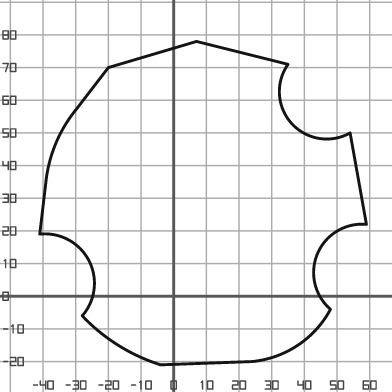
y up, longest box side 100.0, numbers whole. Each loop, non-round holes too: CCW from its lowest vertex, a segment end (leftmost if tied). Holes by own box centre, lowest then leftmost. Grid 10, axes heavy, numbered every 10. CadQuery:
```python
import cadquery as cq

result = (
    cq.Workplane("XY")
    .moveTo(-4.0, -21.0)
    .lineTo(24.0, -20.0)
    .threePointArc((38.0, -15.0), (48.0, -4.0))
    .threePointArc((44.0, 13.0), (59.0, 22.0))
    .lineTo(54.0, 50.0)
    .threePointArc((36.0, 53.0), (35.0, 71.0))
    .lineTo(7.0, 78.0)
    .lineTo(-20.0, 70.0)
    .lineTo(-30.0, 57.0)
    .threePointArc((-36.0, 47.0), (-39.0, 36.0))
    .lineTo(-41.0, 19.0)
    .threePointArc((-26.0, 11.0), (-28.0, -6.0))
    .threePointArc((-17.0, -15.0), (-4.0, -21.0))
    .close()
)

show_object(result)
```